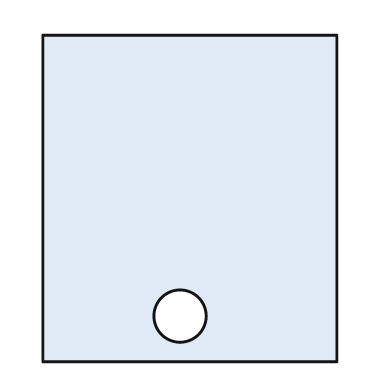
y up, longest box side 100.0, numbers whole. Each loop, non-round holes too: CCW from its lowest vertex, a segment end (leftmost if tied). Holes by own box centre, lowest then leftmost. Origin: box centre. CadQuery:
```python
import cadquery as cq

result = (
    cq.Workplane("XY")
    .moveTo(-45.0, -50.0)
    .lineTo(45.0, -50.0)
    .lineTo(45.0, 50.0)
    .lineTo(-45.0, 50.0)
    .close()
    .moveTo(-3.0, -36.0)
    .circle(8.0)
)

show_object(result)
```